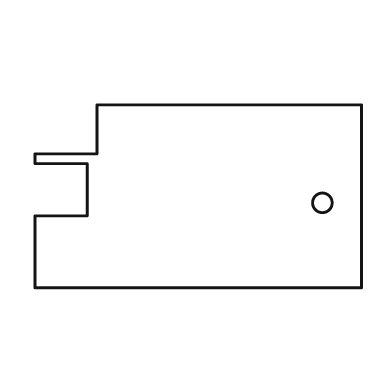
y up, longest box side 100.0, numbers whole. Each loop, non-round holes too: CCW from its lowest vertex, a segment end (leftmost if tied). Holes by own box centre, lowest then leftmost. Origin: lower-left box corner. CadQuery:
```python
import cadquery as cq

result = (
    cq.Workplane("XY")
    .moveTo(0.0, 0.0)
    .lineTo(100.0, 0.0)
    .lineTo(100.0, 56.0)
    .lineTo(19.0, 56.0)
    .lineTo(19.0, 41.0)
    .lineTo(0.0, 41.0)
    .lineTo(0.0, 38.0)
    .lineTo(16.0, 38.0)
    .lineTo(16.0, 22.0)
    .lineTo(0.0, 22.0)
    .close()
    .moveTo(88.0, 26.0)
    .circle(3.0)
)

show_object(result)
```